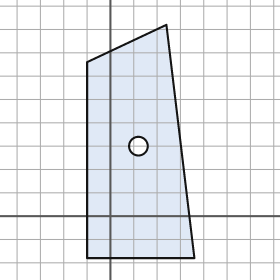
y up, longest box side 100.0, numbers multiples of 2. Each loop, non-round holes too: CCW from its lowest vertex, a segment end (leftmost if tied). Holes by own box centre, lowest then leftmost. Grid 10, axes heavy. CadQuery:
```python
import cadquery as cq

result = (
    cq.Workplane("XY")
    .moveTo(-10.0, -18.0)
    .lineTo(36.0, -18.0)
    .lineTo(24.0, 82.0)
    .lineTo(-10.0, 66.0)
    .close()
    .moveTo(12.0, 30.0)
    .circle(4.0)
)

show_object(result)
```